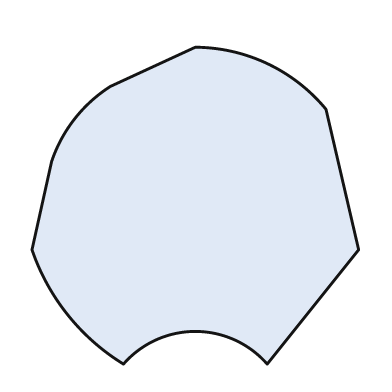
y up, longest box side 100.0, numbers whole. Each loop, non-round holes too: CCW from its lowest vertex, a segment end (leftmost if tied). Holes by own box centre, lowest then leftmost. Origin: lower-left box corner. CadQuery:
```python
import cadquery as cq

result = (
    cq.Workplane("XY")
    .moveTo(28.0, 0.0)
    .threePointArc((50.0, 10.0), (72.0, 0.0))
    .lineTo(100.0, 35.0)
    .lineTo(90.0, 78.0)
    .threePointArc((72.0, 92.0), (50.0, 97.0))
    .lineTo(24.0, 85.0)
    .threePointArc((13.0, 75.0), (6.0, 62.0))
    .lineTo(0.0, 35.0)
    .threePointArc((11.0, 15.0), (28.0, 0.0))
    .close()
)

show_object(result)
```